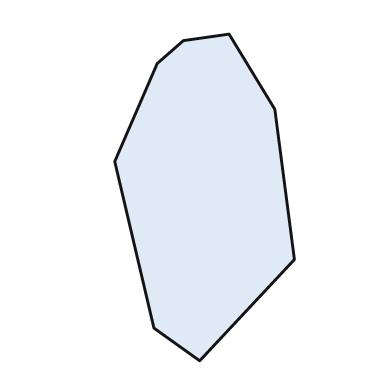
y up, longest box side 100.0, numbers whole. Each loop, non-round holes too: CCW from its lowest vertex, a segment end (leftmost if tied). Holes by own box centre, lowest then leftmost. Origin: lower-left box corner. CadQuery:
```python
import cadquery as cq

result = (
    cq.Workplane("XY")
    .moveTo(26.0, 0.0)
    .lineTo(55.0, 31.0)
    .lineTo(49.0, 77.0)
    .lineTo(35.0, 100.0)
    .lineTo(21.0, 98.0)
    .lineTo(13.0, 91.0)
    .lineTo(0.0, 61.0)
    .lineTo(12.0, 10.0)
    .close()
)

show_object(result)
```